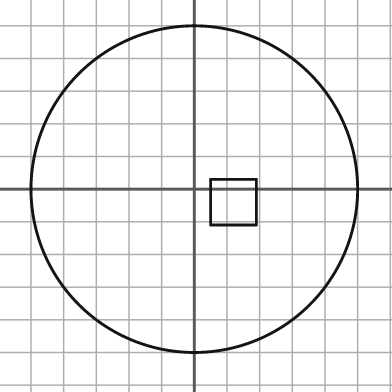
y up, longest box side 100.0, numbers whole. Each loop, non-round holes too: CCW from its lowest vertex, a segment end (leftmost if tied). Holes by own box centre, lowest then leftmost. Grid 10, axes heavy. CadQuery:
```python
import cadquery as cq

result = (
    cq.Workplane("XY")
    .moveTo(0.0, 0.0)
    .circle(50.0)
    .moveTo(5.0, -11.0)
    .lineTo(19.0, -11.0)
    .lineTo(19.0, 3.0)
    .lineTo(5.0, 3.0)
    .close()
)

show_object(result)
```